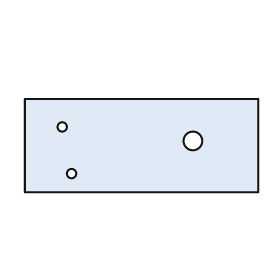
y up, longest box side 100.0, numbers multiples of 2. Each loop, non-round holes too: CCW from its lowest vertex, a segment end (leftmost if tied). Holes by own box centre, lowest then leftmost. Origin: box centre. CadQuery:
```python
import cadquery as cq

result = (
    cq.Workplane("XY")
    .moveTo(-50.0, -20.0)
    .lineTo(50.0, -20.0)
    .lineTo(50.0, 20.0)
    .lineTo(-50.0, 20.0)
    .close()
    .moveTo(-30.0, -12.0)
    .circle(2.0)
    .moveTo(22.0, 2.0)
    .circle(4.0)
    .moveTo(-34.0, 8.0)
    .circle(2.0)
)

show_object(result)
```